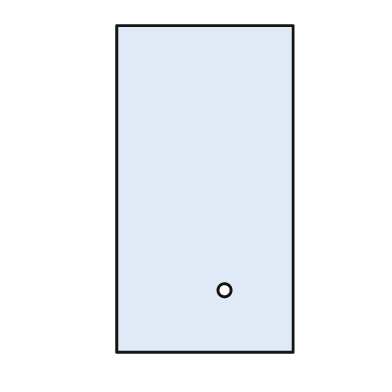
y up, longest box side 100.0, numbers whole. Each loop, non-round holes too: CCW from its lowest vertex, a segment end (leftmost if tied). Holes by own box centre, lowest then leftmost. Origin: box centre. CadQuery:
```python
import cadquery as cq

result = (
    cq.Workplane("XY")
    .moveTo(-27.0, -50.0)
    .lineTo(27.0, -50.0)
    .lineTo(27.0, 50.0)
    .lineTo(-27.0, 50.0)
    .close()
    .moveTo(6.0, -31.0)
    .circle(2.0)
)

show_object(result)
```